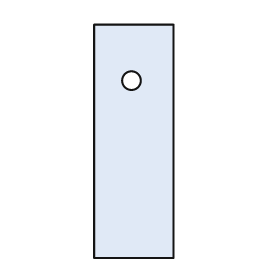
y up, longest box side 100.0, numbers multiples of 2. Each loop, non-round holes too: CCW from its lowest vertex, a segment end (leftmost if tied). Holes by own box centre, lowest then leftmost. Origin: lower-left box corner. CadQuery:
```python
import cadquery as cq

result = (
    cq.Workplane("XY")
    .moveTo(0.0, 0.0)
    .lineTo(34.0, 0.0)
    .lineTo(34.0, 100.0)
    .lineTo(0.0, 100.0)
    .close()
    .moveTo(16.0, 76.0)
    .circle(4.0)
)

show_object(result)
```